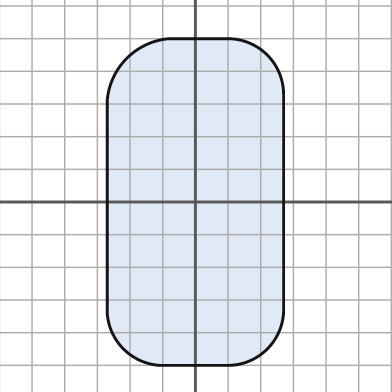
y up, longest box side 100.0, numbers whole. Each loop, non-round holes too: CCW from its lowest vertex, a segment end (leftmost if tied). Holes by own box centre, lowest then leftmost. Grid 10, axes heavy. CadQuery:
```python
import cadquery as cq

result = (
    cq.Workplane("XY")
    .moveTo(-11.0, -50.0)
    .lineTo(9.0, -50.0)
    .threePointArc((22.0, -45.0), (27.0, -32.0))
    .lineTo(27.0, 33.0)
    .threePointArc((22.0, 45.0), (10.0, 50.0))
    .lineTo(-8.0, 50.0)
    .threePointArc((-21.0, 44.0), (-27.0, 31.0))
    .lineTo(-27.0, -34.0)
    .threePointArc((-22.0, -45.0), (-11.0, -50.0))
    .close()
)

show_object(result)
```